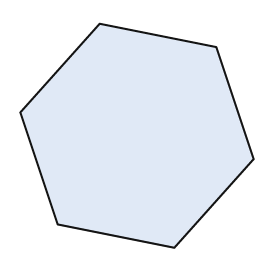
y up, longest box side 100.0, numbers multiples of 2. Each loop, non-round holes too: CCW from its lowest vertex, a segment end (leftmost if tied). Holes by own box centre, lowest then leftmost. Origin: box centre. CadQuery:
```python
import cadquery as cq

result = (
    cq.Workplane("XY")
    .moveTo(16.0, -48.0)
    .lineTo(50.0, -10.0)
    .lineTo(34.0, 38.0)
    .lineTo(-16.0, 48.0)
    .lineTo(-50.0, 10.0)
    .lineTo(-34.0, -38.0)
    .close()
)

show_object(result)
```